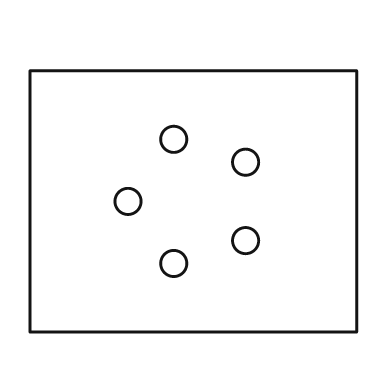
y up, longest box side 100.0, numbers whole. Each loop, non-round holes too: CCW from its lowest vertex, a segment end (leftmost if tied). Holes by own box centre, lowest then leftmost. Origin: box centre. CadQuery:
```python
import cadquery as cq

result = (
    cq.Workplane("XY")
    .moveTo(-50.0, -40.0)
    .lineTo(50.0, -40.0)
    .lineTo(50.0, 40.0)
    .lineTo(-50.0, 40.0)
    .close()
    .moveTo(-6.0, -19.0)
    .circle(4.0)
    .moveTo(16.0, -12.0)
    .circle(4.0)
    .moveTo(-20.0, 0.0)
    .circle(4.0)
    .moveTo(16.0, 12.0)
    .circle(4.0)
    .moveTo(-6.0, 19.0)
    .circle(4.0)
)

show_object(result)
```